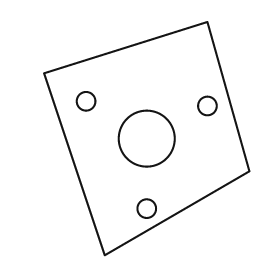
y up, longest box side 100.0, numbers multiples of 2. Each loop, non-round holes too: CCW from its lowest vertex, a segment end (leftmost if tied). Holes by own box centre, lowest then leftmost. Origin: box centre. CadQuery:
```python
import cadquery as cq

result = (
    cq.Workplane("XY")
    .moveTo(-18.0, -50.0)
    .lineTo(44.0, -14.0)
    .lineTo(26.0, 50.0)
    .lineTo(-44.0, 28.0)
    .close()
    .moveTo(0.0, -30.0)
    .circle(4.0)
    .moveTo(0.0, 0.0)
    .circle(12.0)
    .moveTo(26.0, 14.0)
    .circle(4.0)
    .moveTo(-26.0, 16.0)
    .circle(4.0)
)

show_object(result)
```